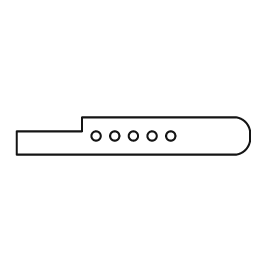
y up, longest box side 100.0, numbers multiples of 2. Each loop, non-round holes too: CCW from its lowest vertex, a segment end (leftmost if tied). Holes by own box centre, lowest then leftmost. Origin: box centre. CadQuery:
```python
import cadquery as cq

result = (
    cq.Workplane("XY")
    .moveTo(-50.0, -8.0)
    .lineTo(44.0, -8.0)
    .threePointArc((48.0, -6.0), (50.0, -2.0))
    .lineTo(50.0, 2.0)
    .threePointArc((48.0, 6.0), (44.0, 8.0))
    .lineTo(-22.0, 8.0)
    .lineTo(-22.0, 2.0)
    .lineTo(-50.0, 2.0)
    .close()
    .moveTo(-16.0, 0.0)
    .circle(2.0)
    .moveTo(-8.0, 0.0)
    .circle(2.0)
    .moveTo(0.0, 0.0)
    .circle(2.0)
    .moveTo(8.0, 0.0)
    .circle(2.0)
    .moveTo(16.0, 0.0)
    .circle(2.0)
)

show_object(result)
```